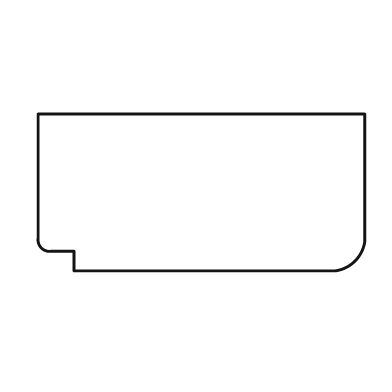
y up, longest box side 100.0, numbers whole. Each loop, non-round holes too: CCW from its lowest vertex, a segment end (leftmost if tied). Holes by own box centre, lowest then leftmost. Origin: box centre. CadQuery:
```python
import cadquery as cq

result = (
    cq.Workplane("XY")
    .moveTo(-39.0, -24.0)
    .lineTo(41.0, -24.0)
    .threePointArc((47.0, -21.0), (50.0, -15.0))
    .lineTo(50.0, 24.0)
    .lineTo(-50.0, 24.0)
    .lineTo(-50.0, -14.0)
    .threePointArc((-49.0, -17.0), (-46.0, -18.0))
    .lineTo(-39.0, -18.0)
    .close()
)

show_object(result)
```